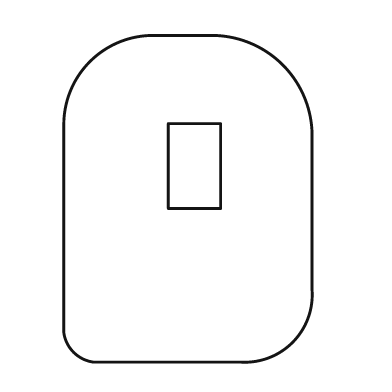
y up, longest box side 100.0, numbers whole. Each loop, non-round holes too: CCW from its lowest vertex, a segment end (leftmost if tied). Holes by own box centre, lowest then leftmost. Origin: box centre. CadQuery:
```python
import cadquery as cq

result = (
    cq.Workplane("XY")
    .moveTo(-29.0, -50.0)
    .lineTo(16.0, -50.0)
    .threePointArc((32.0, -44.0), (38.0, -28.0))
    .lineTo(38.0, 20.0)
    .threePointArc((29.0, 41.0), (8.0, 50.0))
    .lineTo(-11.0, 50.0)
    .threePointArc((-30.0, 42.0), (-38.0, 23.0))
    .lineTo(-38.0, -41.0)
    .threePointArc((-35.0, -47.0), (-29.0, -50.0))
    .close()
    .moveTo(-6.0, -3.0)
    .lineTo(10.0, -3.0)
    .lineTo(10.0, 23.0)
    .lineTo(-6.0, 23.0)
    .close()
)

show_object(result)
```